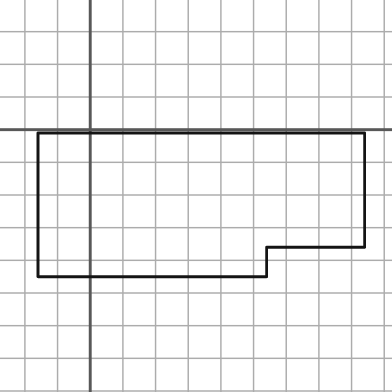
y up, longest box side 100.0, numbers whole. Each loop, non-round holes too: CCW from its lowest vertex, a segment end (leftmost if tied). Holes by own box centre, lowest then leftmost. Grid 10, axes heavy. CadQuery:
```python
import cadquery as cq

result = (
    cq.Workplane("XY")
    .moveTo(-16.0, -45.0)
    .lineTo(54.0, -45.0)
    .lineTo(54.0, -36.0)
    .lineTo(84.0, -36.0)
    .lineTo(84.0, -1.0)
    .lineTo(-16.0, -1.0)
    .close()
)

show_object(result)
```